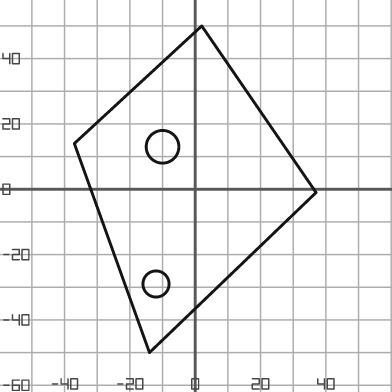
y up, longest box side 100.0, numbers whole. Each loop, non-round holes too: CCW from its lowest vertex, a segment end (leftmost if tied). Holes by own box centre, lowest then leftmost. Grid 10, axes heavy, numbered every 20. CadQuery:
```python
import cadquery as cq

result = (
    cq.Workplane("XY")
    .moveTo(-14.0, -50.0)
    .lineTo(37.0, -1.0)
    .lineTo(2.0, 50.0)
    .lineTo(-37.0, 14.0)
    .close()
    .moveTo(-12.0, -29.0)
    .circle(4.0)
    .moveTo(-10.0, 13.0)
    .circle(5.0)
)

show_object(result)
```